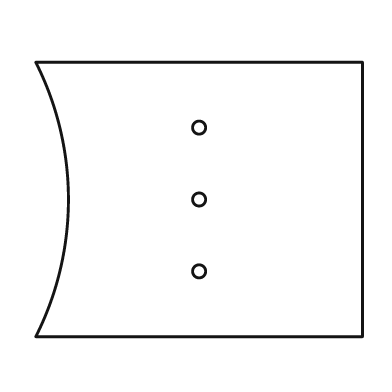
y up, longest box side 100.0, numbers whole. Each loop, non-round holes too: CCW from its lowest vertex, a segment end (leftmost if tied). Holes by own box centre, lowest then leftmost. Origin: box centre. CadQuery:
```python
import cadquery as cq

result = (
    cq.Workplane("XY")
    .moveTo(-50.0, -42.0)
    .lineTo(50.0, -42.0)
    .lineTo(50.0, 42.0)
    .lineTo(-50.0, 42.0)
    .threePointArc((-40.0, 0.0), (-50.0, -42.0))
    .close()
    .moveTo(0.0, -22.0)
    .circle(2.0)
    .moveTo(0.0, 0.0)
    .circle(2.0)
    .moveTo(0.0, 22.0)
    .circle(2.0)
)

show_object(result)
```